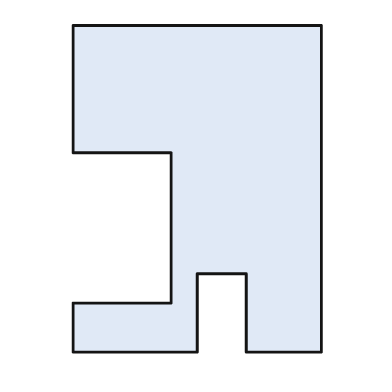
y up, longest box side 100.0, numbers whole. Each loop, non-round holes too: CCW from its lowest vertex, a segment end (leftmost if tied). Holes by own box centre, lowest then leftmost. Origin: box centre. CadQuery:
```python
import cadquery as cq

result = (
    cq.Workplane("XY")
    .moveTo(-38.0, -50.0)
    .lineTo(0.0, -50.0)
    .lineTo(0.0, -26.0)
    .lineTo(15.0, -26.0)
    .lineTo(15.0, -50.0)
    .lineTo(38.0, -50.0)
    .lineTo(38.0, 50.0)
    .lineTo(-38.0, 50.0)
    .lineTo(-38.0, 11.0)
    .lineTo(-8.0, 11.0)
    .lineTo(-8.0, -35.0)
    .lineTo(-38.0, -35.0)
    .close()
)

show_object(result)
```